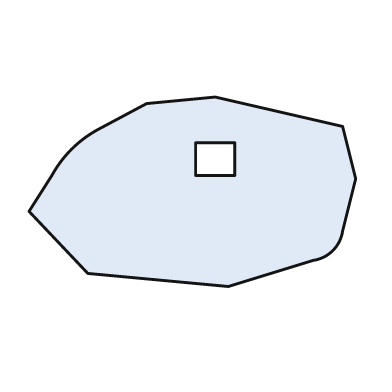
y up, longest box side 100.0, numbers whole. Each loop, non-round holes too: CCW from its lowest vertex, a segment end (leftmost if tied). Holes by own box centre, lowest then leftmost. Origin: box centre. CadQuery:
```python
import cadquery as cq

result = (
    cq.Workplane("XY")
    .moveTo(11.0, -29.0)
    .lineTo(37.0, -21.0)
    .threePointArc((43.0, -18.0), (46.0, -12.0))
    .lineTo(50.0, 4.0)
    .lineTo(46.0, 20.0)
    .lineTo(7.0, 29.0)
    .lineTo(-14.0, 27.0)
    .lineTo(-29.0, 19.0)
    .threePointArc((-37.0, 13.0), (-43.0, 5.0))
    .lineTo(-50.0, -6.0)
    .lineTo(-32.0, -25.0)
    .close()
    .moveTo(1.0, 5.0)
    .lineTo(13.0, 5.0)
    .lineTo(13.0, 15.0)
    .lineTo(1.0, 15.0)
    .close()
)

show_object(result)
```